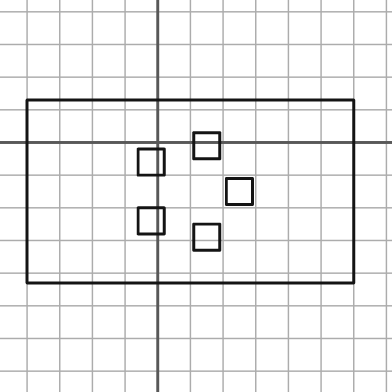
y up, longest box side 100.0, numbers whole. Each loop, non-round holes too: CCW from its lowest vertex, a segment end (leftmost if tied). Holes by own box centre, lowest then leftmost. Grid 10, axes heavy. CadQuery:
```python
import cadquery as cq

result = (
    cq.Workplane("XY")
    .moveTo(-40.0, -43.0)
    .lineTo(60.0, -43.0)
    .lineTo(60.0, 13.0)
    .lineTo(-40.0, 13.0)
    .close()
    .moveTo(11.0, -33.0)
    .lineTo(19.0, -33.0)
    .lineTo(19.0, -25.0)
    .lineTo(11.0, -25.0)
    .close()
    .moveTo(-6.0, -28.0)
    .lineTo(2.0, -28.0)
    .lineTo(2.0, -20.0)
    .lineTo(-6.0, -20.0)
    .close()
    .moveTo(21.0, -19.0)
    .lineTo(29.0, -19.0)
    .lineTo(29.0, -11.0)
    .lineTo(21.0, -11.0)
    .close()
    .moveTo(-6.0, -10.0)
    .lineTo(2.0, -10.0)
    .lineTo(2.0, -2.0)
    .lineTo(-6.0, -2.0)
    .close()
    .moveTo(11.0, -5.0)
    .lineTo(19.0, -5.0)
    .lineTo(19.0, 3.0)
    .lineTo(11.0, 3.0)
    .close()
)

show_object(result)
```